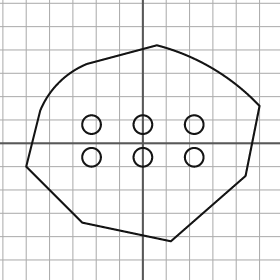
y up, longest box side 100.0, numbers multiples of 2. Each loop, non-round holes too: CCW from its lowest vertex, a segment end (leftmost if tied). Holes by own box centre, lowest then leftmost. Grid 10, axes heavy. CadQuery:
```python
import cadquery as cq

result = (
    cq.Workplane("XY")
    .moveTo(12.0, -42.0)
    .lineTo(44.0, -14.0)
    .lineTo(50.0, 16.0)
    .threePointArc((30.0, 32.0), (6.0, 42.0))
    .lineTo(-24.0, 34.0)
    .threePointArc((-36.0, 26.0), (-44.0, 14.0))
    .lineTo(-50.0, -10.0)
    .lineTo(-26.0, -34.0)
    .close()
    .moveTo(-22.0, -6.0)
    .circle(4.0)
    .moveTo(0.0, -6.0)
    .circle(4.0)
    .moveTo(22.0, -6.0)
    .circle(4.0)
    .moveTo(-22.0, 8.0)
    .circle(4.0)
    .moveTo(0.0, 8.0)
    .circle(4.0)
    .moveTo(22.0, 8.0)
    .circle(4.0)
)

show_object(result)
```